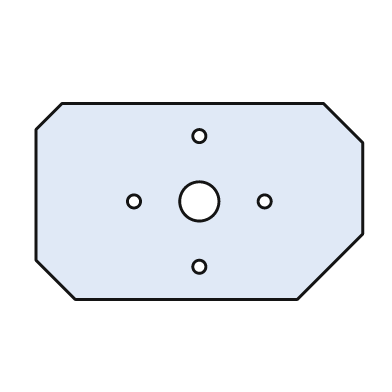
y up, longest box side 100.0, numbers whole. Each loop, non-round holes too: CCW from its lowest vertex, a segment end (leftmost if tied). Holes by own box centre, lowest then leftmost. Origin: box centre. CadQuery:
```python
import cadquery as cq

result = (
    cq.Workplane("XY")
    .moveTo(-38.0, -30.0)
    .lineTo(30.0, -30.0)
    .lineTo(50.0, -10.0)
    .lineTo(50.0, 18.0)
    .lineTo(38.0, 30.0)
    .lineTo(-42.0, 30.0)
    .lineTo(-50.0, 22.0)
    .lineTo(-50.0, -18.0)
    .close()
    .moveTo(0.0, -20.0)
    .circle(2.0)
    .moveTo(-20.0, 0.0)
    .circle(2.0)
    .moveTo(0.0, 0.0)
    .circle(6.0)
    .moveTo(20.0, 0.0)
    .circle(2.0)
    .moveTo(0.0, 20.0)
    .circle(2.0)
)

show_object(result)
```